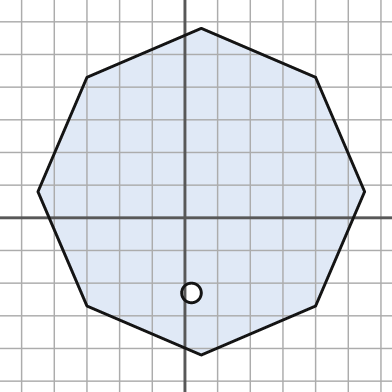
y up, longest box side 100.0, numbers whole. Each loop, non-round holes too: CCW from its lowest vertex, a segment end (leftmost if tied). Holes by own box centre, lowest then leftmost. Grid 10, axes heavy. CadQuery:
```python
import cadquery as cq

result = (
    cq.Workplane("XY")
    .moveTo(5.0, -42.0)
    .lineTo(40.0, -27.0)
    .lineTo(55.0, 8.0)
    .lineTo(40.0, 43.0)
    .lineTo(5.0, 58.0)
    .lineTo(-30.0, 43.0)
    .lineTo(-45.0, 8.0)
    .lineTo(-30.0, -27.0)
    .close()
    .moveTo(2.0, -23.0)
    .circle(3.0)
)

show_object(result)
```